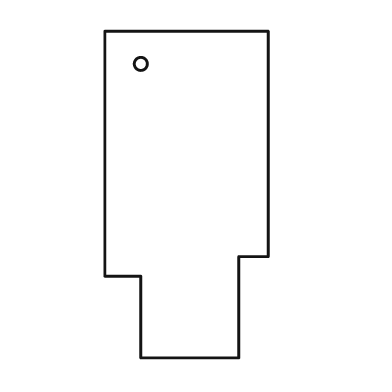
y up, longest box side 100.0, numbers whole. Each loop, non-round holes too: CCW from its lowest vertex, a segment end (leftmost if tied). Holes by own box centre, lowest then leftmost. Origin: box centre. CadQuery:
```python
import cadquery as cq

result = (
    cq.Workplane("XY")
    .moveTo(-14.0, -50.0)
    .lineTo(16.0, -50.0)
    .lineTo(16.0, -19.0)
    .lineTo(25.0, -19.0)
    .lineTo(25.0, 50.0)
    .lineTo(-25.0, 50.0)
    .lineTo(-25.0, -25.0)
    .lineTo(-14.0, -25.0)
    .close()
    .moveTo(-14.0, 40.0)
    .circle(2.0)
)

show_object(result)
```